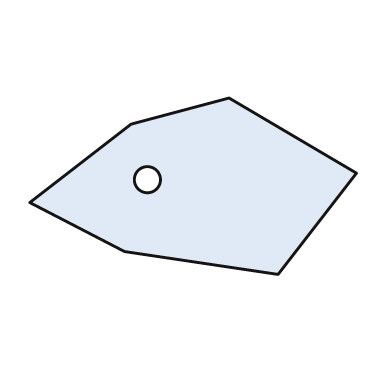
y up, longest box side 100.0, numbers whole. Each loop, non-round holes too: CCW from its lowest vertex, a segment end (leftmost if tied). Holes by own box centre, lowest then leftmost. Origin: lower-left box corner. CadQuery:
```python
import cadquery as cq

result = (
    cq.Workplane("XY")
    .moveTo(76.0, 0.0)
    .lineTo(100.0, 31.0)
    .lineTo(61.0, 54.0)
    .lineTo(31.0, 46.0)
    .lineTo(0.0, 22.0)
    .lineTo(29.0, 7.0)
    .close()
    .moveTo(36.0, 29.0)
    .circle(4.0)
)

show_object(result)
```